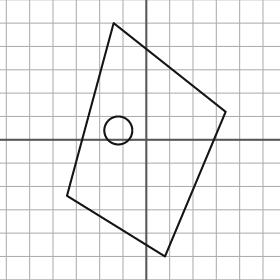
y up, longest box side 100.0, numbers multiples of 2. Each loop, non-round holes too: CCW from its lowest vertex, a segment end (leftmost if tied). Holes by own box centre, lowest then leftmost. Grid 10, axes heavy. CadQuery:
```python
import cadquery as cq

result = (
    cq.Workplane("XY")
    .moveTo(8.0, -50.0)
    .lineTo(34.0, 12.0)
    .lineTo(-14.0, 50.0)
    .lineTo(-34.0, -24.0)
    .close()
    .moveTo(-12.0, 4.0)
    .circle(6.0)
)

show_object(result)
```